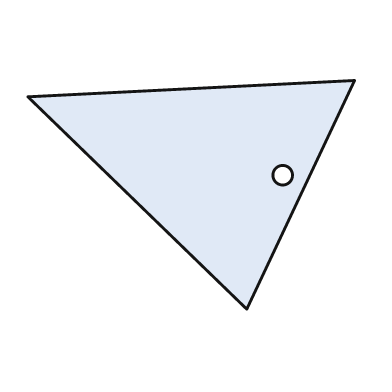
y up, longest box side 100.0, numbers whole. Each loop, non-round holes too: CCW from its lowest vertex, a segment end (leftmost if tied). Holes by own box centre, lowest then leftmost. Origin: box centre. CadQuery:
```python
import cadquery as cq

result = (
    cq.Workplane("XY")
    .moveTo(17.0, -35.0)
    .lineTo(50.0, 35.0)
    .lineTo(-50.0, 30.0)
    .close()
    .moveTo(28.0, 6.0)
    .circle(3.0)
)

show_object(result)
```